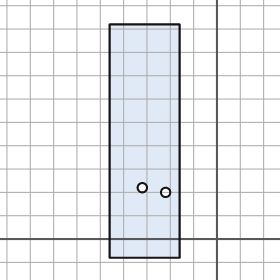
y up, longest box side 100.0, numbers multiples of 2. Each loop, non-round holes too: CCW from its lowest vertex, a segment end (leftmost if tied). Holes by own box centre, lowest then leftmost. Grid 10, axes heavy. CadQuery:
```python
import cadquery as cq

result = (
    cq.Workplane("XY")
    .moveTo(-46.0, -8.0)
    .lineTo(-16.0, -8.0)
    .lineTo(-16.0, 92.0)
    .lineTo(-46.0, 92.0)
    .close()
    .moveTo(-22.0, 20.0)
    .circle(2.0)
    .moveTo(-32.0, 22.0)
    .circle(2.0)
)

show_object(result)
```